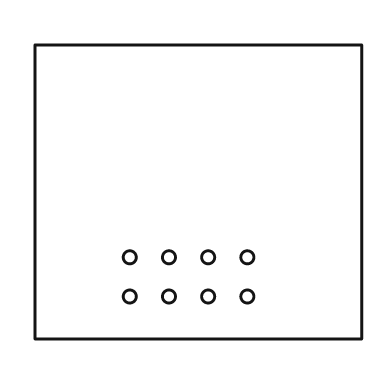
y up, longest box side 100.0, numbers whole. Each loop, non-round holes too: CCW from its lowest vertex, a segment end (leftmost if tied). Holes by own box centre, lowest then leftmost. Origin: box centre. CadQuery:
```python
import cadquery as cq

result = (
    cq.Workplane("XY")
    .moveTo(-50.0, -45.0)
    .lineTo(50.0, -45.0)
    .lineTo(50.0, 45.0)
    .lineTo(-50.0, 45.0)
    .close()
    .moveTo(-21.0, -32.0)
    .circle(2.0)
    .moveTo(-9.0, -32.0)
    .circle(2.0)
    .moveTo(3.0, -32.0)
    .circle(2.0)
    .moveTo(15.0, -32.0)
    .circle(2.0)
    .moveTo(-21.0, -20.0)
    .circle(2.0)
    .moveTo(-9.0, -20.0)
    .circle(2.0)
    .moveTo(3.0, -20.0)
    .circle(2.0)
    .moveTo(15.0, -20.0)
    .circle(2.0)
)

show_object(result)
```